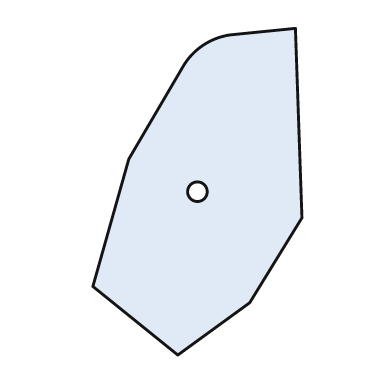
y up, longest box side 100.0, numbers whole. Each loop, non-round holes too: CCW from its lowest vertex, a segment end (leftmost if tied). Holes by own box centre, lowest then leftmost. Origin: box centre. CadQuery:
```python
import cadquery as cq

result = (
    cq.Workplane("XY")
    .moveTo(-6.0, -50.0)
    .lineTo(16.0, -34.0)
    .lineTo(32.0, -8.0)
    .lineTo(30.0, 50.0)
    .lineTo(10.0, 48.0)
    .threePointArc((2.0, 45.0), (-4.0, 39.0))
    .lineTo(-21.0, 10.0)
    .lineTo(-32.0, -29.0)
    .close()
    .moveTo(0.0, 0.0)
    .circle(3.0)
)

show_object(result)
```